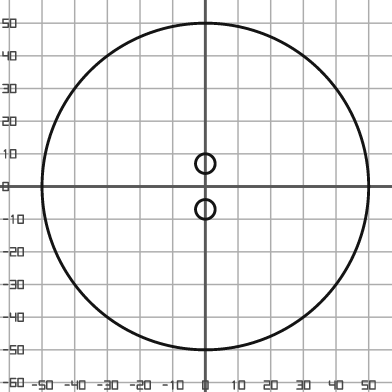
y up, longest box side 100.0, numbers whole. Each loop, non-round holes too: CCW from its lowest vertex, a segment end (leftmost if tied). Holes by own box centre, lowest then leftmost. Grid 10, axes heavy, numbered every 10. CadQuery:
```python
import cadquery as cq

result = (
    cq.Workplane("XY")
    .moveTo(0.0, 0.0)
    .circle(50.0)
    .moveTo(0.0, -7.0)
    .circle(3.0)
    .moveTo(0.0, 7.0)
    .circle(3.0)
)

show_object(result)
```